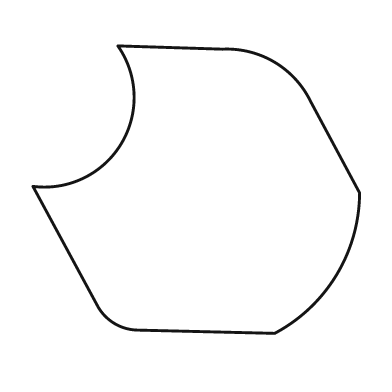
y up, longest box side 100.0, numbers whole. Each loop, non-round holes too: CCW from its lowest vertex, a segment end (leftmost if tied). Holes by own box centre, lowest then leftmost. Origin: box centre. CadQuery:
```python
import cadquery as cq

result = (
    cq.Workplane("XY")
    .moveTo(24.0, -44.0)
    .threePointArc((43.0, -26.0), (50.0, -1.0))
    .lineTo(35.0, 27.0)
    .threePointArc((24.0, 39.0), (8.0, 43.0))
    .lineTo(-24.0, 44.0)
    .threePointArc((-23.0, 14.0), (-50.0, 1.0))
    .lineTo(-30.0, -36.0)
    .threePointArc((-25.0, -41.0), (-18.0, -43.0))
    .close()
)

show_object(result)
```